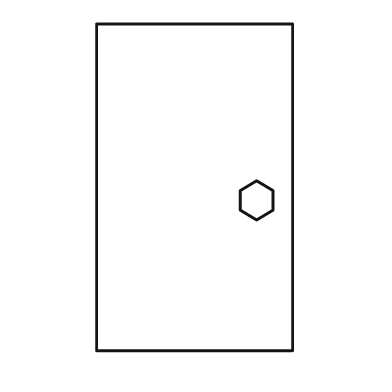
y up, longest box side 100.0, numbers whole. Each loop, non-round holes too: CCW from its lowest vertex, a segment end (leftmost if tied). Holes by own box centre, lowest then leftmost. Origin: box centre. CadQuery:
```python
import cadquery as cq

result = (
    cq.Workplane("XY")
    .moveTo(-30.0, -50.0)
    .lineTo(30.0, -50.0)
    .lineTo(30.0, 50.0)
    .lineTo(-30.0, 50.0)
    .close()
    .moveTo(19.0, -10.0)
    .lineTo(24.0, -7.0)
    .lineTo(24.0, -1.0)
    .lineTo(19.0, 2.0)
    .lineTo(14.0, -1.0)
    .lineTo(14.0, -7.0)
    .close()
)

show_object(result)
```